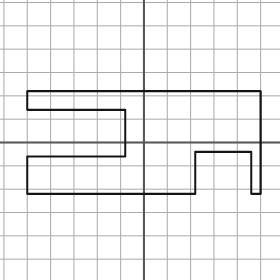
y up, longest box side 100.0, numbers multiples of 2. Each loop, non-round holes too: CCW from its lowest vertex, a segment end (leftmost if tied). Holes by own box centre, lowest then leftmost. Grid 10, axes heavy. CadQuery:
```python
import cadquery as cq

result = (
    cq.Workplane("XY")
    .moveTo(-50.0, -22.0)
    .lineTo(22.0, -22.0)
    .lineTo(22.0, -4.0)
    .lineTo(46.0, -4.0)
    .lineTo(46.0, -22.0)
    .lineTo(50.0, -22.0)
    .lineTo(50.0, 22.0)
    .lineTo(-50.0, 22.0)
    .lineTo(-50.0, 14.0)
    .lineTo(-8.0, 14.0)
    .lineTo(-8.0, -6.0)
    .lineTo(-50.0, -6.0)
    .close()
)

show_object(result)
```